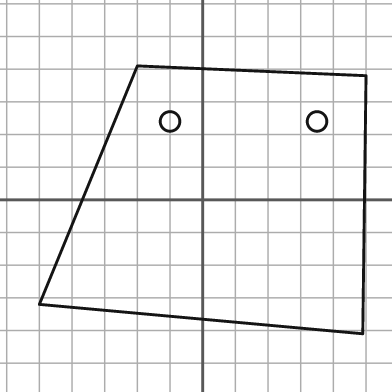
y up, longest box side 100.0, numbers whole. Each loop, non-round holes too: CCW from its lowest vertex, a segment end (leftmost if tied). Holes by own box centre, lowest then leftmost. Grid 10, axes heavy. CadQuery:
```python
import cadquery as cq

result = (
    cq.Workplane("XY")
    .moveTo(49.0, -41.0)
    .lineTo(50.0, 38.0)
    .lineTo(-20.0, 41.0)
    .lineTo(-50.0, -32.0)
    .close()
    .moveTo(-10.0, 24.0)
    .circle(3.0)
    .moveTo(35.0, 24.0)
    .circle(3.0)
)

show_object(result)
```